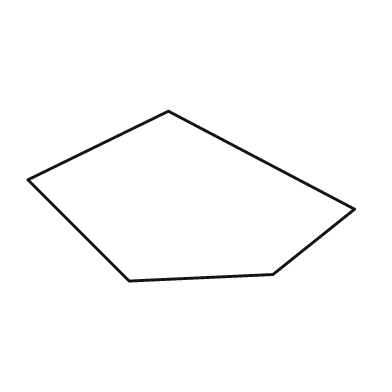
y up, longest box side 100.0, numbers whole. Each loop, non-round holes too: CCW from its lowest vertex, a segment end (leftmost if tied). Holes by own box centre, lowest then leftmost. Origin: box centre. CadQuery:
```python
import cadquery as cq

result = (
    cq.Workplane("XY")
    .moveTo(-19.0, -26.0)
    .lineTo(25.0, -24.0)
    .lineTo(50.0, -4.0)
    .lineTo(-7.0, 26.0)
    .lineTo(-50.0, 5.0)
    .close()
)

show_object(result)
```